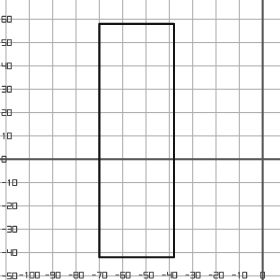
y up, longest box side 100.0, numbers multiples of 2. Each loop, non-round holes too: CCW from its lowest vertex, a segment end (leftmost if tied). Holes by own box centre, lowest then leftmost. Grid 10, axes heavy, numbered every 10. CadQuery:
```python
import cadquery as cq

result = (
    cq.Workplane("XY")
    .moveTo(-70.0, -42.0)
    .lineTo(-38.0, -42.0)
    .lineTo(-38.0, 58.0)
    .lineTo(-70.0, 58.0)
    .close()
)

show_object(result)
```